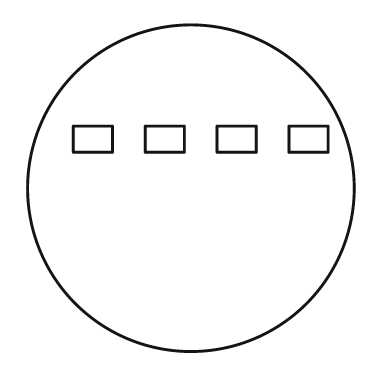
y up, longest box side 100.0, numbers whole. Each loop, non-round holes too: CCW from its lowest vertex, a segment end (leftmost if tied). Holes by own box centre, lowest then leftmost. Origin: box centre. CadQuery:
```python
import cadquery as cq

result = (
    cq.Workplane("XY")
    .moveTo(0.0, 0.0)
    .circle(50.0)
    .moveTo(-36.0, 11.0)
    .lineTo(-24.0, 11.0)
    .lineTo(-24.0, 19.0)
    .lineTo(-36.0, 19.0)
    .close()
    .moveTo(-14.0, 11.0)
    .lineTo(-2.0, 11.0)
    .lineTo(-2.0, 19.0)
    .lineTo(-14.0, 19.0)
    .close()
    .moveTo(8.0, 11.0)
    .lineTo(20.0, 11.0)
    .lineTo(20.0, 19.0)
    .lineTo(8.0, 19.0)
    .close()
    .moveTo(30.0, 11.0)
    .lineTo(42.0, 11.0)
    .lineTo(42.0, 19.0)
    .lineTo(30.0, 19.0)
    .close()
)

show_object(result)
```